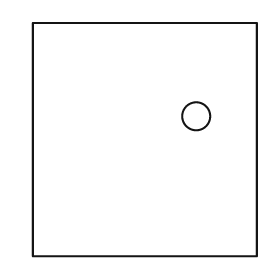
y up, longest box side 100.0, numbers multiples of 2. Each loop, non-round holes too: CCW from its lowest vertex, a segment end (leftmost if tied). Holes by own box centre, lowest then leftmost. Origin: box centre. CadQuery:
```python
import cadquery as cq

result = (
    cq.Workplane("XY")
    .moveTo(-48.0, -50.0)
    .lineTo(48.0, -50.0)
    .lineTo(48.0, 50.0)
    .lineTo(-48.0, 50.0)
    .close()
    .moveTo(22.0, 10.0)
    .circle(6.0)
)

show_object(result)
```